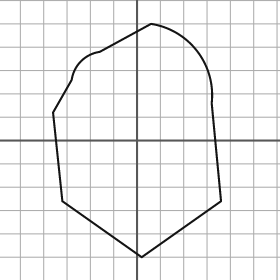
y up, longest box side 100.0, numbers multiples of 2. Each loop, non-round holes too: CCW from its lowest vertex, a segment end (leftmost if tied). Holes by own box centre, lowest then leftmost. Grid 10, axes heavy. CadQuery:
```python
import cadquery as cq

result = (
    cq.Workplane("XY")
    .moveTo(2.0, -50.0)
    .lineTo(36.0, -26.0)
    .lineTo(32.0, 16.0)
    .threePointArc((26.0, 38.0), (6.0, 50.0))
    .lineTo(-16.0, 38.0)
    .threePointArc((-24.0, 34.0), (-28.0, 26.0))
    .lineTo(-36.0, 12.0)
    .lineTo(-32.0, -26.0)
    .close()
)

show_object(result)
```